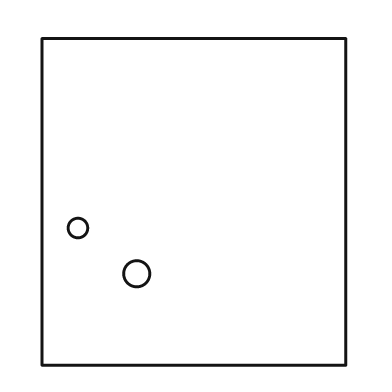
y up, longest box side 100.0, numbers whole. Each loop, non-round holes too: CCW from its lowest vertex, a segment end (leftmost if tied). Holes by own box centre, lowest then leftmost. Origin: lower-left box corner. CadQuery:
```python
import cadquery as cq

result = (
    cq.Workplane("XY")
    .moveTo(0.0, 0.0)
    .lineTo(93.0, 0.0)
    .lineTo(93.0, 100.0)
    .lineTo(0.0, 100.0)
    .close()
    .moveTo(29.0, 28.0)
    .circle(4.0)
    .moveTo(11.0, 42.0)
    .circle(3.0)
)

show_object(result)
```